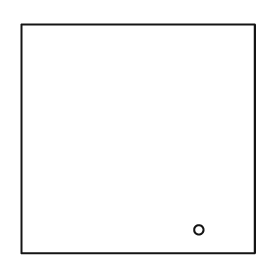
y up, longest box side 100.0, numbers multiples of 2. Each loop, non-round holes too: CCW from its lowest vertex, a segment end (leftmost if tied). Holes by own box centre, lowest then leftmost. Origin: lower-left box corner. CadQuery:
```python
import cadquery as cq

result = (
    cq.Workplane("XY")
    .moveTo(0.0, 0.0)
    .lineTo(100.0, 0.0)
    .lineTo(100.0, 98.0)
    .lineTo(0.0, 98.0)
    .close()
    .moveTo(76.0, 10.0)
    .circle(2.0)
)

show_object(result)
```